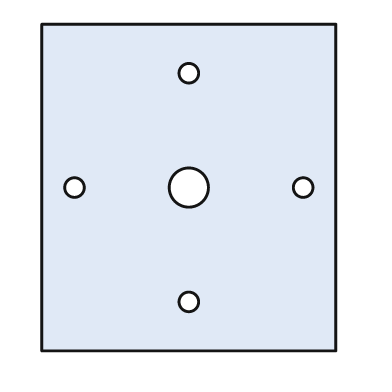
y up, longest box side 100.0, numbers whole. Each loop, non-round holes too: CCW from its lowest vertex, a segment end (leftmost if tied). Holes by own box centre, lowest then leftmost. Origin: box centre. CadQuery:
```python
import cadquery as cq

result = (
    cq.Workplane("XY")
    .moveTo(-45.0, -50.0)
    .lineTo(45.0, -50.0)
    .lineTo(45.0, 50.0)
    .lineTo(-45.0, 50.0)
    .close()
    .moveTo(0.0, -35.0)
    .circle(3.0)
    .moveTo(-35.0, 0.0)
    .circle(3.0)
    .moveTo(0.0, 0.0)
    .circle(6.0)
    .moveTo(35.0, 0.0)
    .circle(3.0)
    .moveTo(0.0, 35.0)
    .circle(3.0)
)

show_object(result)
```